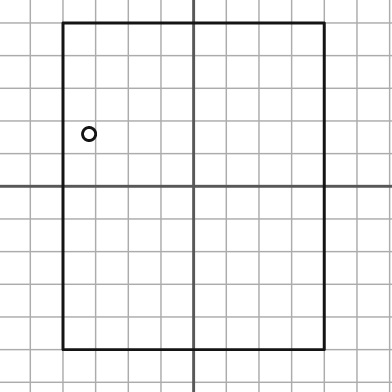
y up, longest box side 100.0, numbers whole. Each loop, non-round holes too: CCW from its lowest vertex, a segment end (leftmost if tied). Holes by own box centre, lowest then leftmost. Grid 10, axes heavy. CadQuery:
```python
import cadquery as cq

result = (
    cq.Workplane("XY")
    .moveTo(-40.0, -50.0)
    .lineTo(40.0, -50.0)
    .lineTo(40.0, 50.0)
    .lineTo(-40.0, 50.0)
    .close()
    .moveTo(-32.0, 16.0)
    .circle(2.0)
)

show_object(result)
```